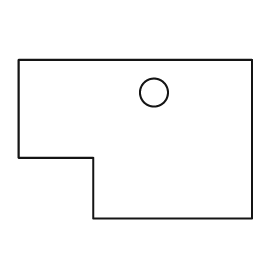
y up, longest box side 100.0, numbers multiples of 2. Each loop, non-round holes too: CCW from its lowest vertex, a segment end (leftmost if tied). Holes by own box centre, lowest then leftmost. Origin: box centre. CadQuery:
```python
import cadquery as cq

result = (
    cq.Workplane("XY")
    .moveTo(-18.0, -34.0)
    .lineTo(50.0, -34.0)
    .lineTo(50.0, 34.0)
    .lineTo(-50.0, 34.0)
    .lineTo(-50.0, -8.0)
    .lineTo(-18.0, -8.0)
    .close()
    .moveTo(8.0, 20.0)
    .circle(6.0)
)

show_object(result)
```